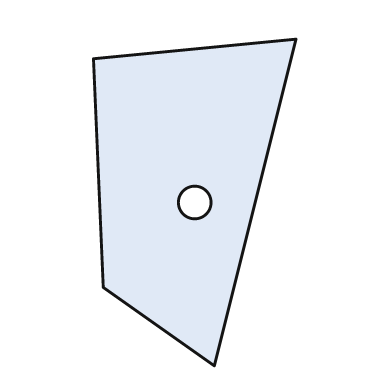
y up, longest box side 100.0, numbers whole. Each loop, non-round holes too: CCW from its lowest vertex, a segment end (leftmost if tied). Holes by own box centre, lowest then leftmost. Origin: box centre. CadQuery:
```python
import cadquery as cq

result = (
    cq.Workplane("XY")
    .moveTo(6.0, -50.0)
    .lineTo(31.0, 50.0)
    .lineTo(-31.0, 44.0)
    .lineTo(-28.0, -26.0)
    .close()
    .moveTo(0.0, 0.0)
    .circle(5.0)
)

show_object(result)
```